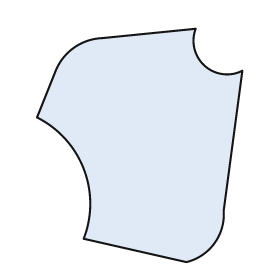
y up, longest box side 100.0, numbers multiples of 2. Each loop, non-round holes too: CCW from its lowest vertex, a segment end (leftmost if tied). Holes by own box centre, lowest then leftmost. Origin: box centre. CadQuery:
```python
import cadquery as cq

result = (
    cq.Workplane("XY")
    .moveTo(20.0, -50.0)
    .threePointArc((32.0, -42.0), (36.0, -28.0))
    .lineTo(44.0, 32.0)
    .threePointArc((28.0, 34.0), (24.0, 50.0))
    .lineTo(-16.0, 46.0)
    .threePointArc((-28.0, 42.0), (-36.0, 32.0))
    .lineTo(-44.0, 12.0)
    .threePointArc((-24.0, -10.0), (-24.0, -40.0))
    .close()
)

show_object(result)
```